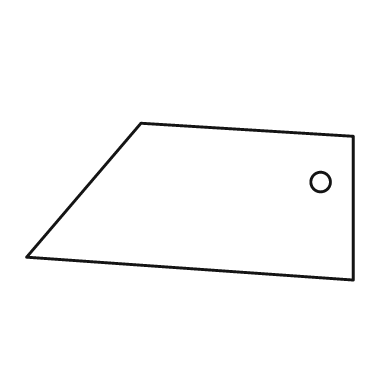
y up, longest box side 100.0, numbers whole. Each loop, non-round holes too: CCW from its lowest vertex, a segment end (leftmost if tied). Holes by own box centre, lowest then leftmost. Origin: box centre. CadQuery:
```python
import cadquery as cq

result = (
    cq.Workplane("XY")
    .moveTo(50.0, -24.0)
    .lineTo(50.0, 20.0)
    .lineTo(-15.0, 24.0)
    .lineTo(-50.0, -17.0)
    .close()
    .moveTo(40.0, 6.0)
    .circle(3.0)
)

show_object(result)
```